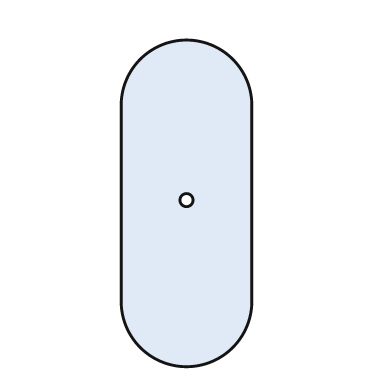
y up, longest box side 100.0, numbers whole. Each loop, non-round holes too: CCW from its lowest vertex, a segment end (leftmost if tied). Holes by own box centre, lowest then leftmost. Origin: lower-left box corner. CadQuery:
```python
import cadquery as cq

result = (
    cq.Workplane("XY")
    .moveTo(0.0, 20.0)
    .threePointArc((20.0, 0.0), (40.0, 20.0))
    .lineTo(40.0, 80.0)
    .threePointArc((20.0, 100.0), (0.0, 80.0))
    .close()
    .moveTo(20.0, 51.0)
    .circle(2.0)
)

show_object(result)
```